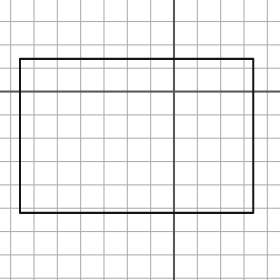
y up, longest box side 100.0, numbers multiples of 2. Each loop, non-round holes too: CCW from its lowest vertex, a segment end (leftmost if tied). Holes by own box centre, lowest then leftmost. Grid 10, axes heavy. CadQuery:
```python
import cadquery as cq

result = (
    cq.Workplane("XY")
    .moveTo(-66.0, -52.0)
    .lineTo(34.0, -52.0)
    .lineTo(34.0, 14.0)
    .lineTo(-66.0, 14.0)
    .close()
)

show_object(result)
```